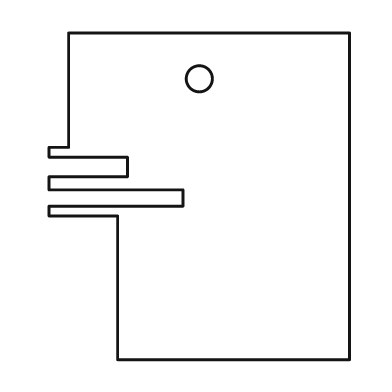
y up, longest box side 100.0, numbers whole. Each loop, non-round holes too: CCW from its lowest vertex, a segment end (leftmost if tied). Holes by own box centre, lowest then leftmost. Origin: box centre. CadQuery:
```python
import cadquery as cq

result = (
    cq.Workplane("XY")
    .moveTo(-25.0, -50.0)
    .lineTo(46.0, -50.0)
    .lineTo(46.0, 50.0)
    .lineTo(-40.0, 50.0)
    .lineTo(-40.0, 15.0)
    .lineTo(-46.0, 15.0)
    .lineTo(-46.0, 12.0)
    .lineTo(-22.0, 12.0)
    .lineTo(-22.0, 6.0)
    .lineTo(-46.0, 6.0)
    .lineTo(-46.0, 2.0)
    .lineTo(-5.0, 2.0)
    .lineTo(-5.0, -3.0)
    .lineTo(-46.0, -3.0)
    .lineTo(-46.0, -6.0)
    .lineTo(-25.0, -6.0)
    .close()
    .moveTo(0.0, 36.0)
    .circle(4.0)
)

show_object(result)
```